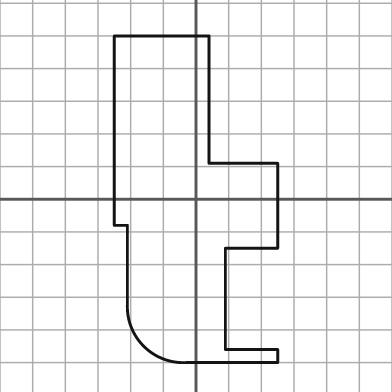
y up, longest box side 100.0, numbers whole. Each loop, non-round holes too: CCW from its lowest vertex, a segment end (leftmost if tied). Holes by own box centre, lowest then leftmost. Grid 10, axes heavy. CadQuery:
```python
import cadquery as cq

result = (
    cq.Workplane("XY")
    .moveTo(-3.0, -50.0)
    .lineTo(25.0, -50.0)
    .lineTo(25.0, -46.0)
    .lineTo(9.0, -46.0)
    .lineTo(9.0, -15.0)
    .lineTo(25.0, -15.0)
    .lineTo(25.0, 11.0)
    .lineTo(4.0, 11.0)
    .lineTo(4.0, 50.0)
    .lineTo(-25.0, 50.0)
    .lineTo(-25.0, -8.0)
    .lineTo(-21.0, -8.0)
    .lineTo(-21.0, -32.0)
    .threePointArc((-16.0, -45.0), (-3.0, -50.0))
    .close()
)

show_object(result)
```